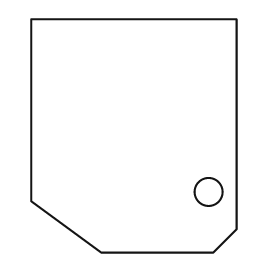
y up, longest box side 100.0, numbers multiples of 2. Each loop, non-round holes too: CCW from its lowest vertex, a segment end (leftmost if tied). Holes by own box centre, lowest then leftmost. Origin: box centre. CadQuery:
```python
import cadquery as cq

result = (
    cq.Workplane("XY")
    .moveTo(-14.0, -50.0)
    .lineTo(34.0, -50.0)
    .lineTo(44.0, -40.0)
    .lineTo(44.0, 50.0)
    .lineTo(-44.0, 50.0)
    .lineTo(-44.0, -28.0)
    .close()
    .moveTo(32.0, -24.0)
    .circle(6.0)
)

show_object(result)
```